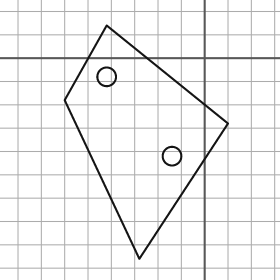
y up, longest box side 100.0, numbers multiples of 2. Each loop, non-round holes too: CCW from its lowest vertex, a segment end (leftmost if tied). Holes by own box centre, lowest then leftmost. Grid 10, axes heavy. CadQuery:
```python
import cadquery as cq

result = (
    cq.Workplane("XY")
    .moveTo(-28.0, -86.0)
    .lineTo(10.0, -28.0)
    .lineTo(-42.0, 14.0)
    .lineTo(-60.0, -18.0)
    .close()
    .moveTo(-14.0, -42.0)
    .circle(4.0)
    .moveTo(-42.0, -8.0)
    .circle(4.0)
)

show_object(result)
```